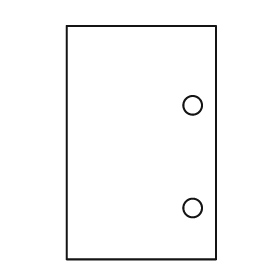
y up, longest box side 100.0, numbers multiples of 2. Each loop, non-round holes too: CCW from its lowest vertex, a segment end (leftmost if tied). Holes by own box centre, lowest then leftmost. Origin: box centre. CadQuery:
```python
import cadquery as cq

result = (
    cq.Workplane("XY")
    .moveTo(-32.0, -50.0)
    .lineTo(32.0, -50.0)
    .lineTo(32.0, 50.0)
    .lineTo(-32.0, 50.0)
    .close()
    .moveTo(22.0, -28.0)
    .circle(4.0)
    .moveTo(22.0, 16.0)
    .circle(4.0)
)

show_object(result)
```